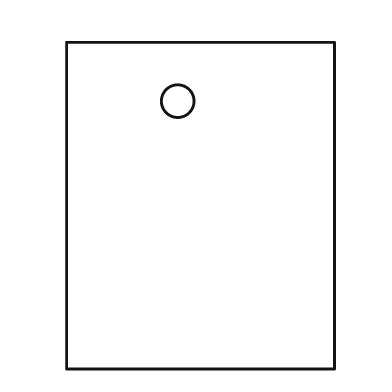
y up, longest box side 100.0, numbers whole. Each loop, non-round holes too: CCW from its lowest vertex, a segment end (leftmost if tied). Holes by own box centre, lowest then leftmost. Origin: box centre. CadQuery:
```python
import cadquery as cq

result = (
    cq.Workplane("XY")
    .moveTo(-41.0, -50.0)
    .lineTo(41.0, -50.0)
    .lineTo(41.0, 50.0)
    .lineTo(-41.0, 50.0)
    .close()
    .moveTo(-7.0, 32.0)
    .circle(5.0)
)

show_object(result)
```